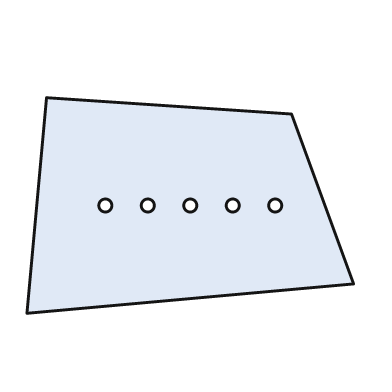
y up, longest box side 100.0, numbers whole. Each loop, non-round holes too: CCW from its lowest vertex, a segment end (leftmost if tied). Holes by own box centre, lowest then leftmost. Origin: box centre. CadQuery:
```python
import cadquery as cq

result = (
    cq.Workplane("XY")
    .moveTo(-50.0, -33.0)
    .lineTo(50.0, -24.0)
    .lineTo(31.0, 28.0)
    .lineTo(-44.0, 33.0)
    .close()
    .moveTo(-26.0, 0.0)
    .circle(2.0)
    .moveTo(-13.0, 0.0)
    .circle(2.0)
    .moveTo(0.0, 0.0)
    .circle(2.0)
    .moveTo(13.0, 0.0)
    .circle(2.0)
    .moveTo(26.0, 0.0)
    .circle(2.0)
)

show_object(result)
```